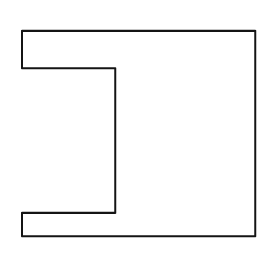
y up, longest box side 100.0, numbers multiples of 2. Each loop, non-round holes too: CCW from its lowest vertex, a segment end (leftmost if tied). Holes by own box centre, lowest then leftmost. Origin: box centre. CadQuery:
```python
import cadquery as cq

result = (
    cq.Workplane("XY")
    .moveTo(-50.0, -44.0)
    .lineTo(50.0, -44.0)
    .lineTo(50.0, 44.0)
    .lineTo(-50.0, 44.0)
    .lineTo(-50.0, 28.0)
    .lineTo(-10.0, 28.0)
    .lineTo(-10.0, -34.0)
    .lineTo(-50.0, -34.0)
    .close()
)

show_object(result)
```